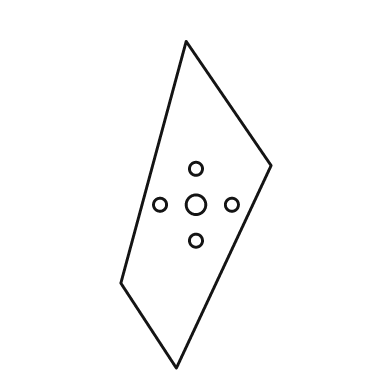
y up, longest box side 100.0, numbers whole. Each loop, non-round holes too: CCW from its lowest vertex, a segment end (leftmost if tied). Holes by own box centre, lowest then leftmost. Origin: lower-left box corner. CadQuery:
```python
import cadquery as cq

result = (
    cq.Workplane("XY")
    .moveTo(17.0, 0.0)
    .lineTo(46.0, 62.0)
    .lineTo(20.0, 100.0)
    .lineTo(0.0, 26.0)
    .close()
    .moveTo(23.0, 39.0)
    .circle(2.0)
    .moveTo(12.0, 50.0)
    .circle(2.0)
    .moveTo(23.0, 50.0)
    .circle(3.0)
    .moveTo(34.0, 50.0)
    .circle(2.0)
    .moveTo(23.0, 61.0)
    .circle(2.0)
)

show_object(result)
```